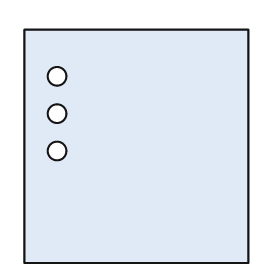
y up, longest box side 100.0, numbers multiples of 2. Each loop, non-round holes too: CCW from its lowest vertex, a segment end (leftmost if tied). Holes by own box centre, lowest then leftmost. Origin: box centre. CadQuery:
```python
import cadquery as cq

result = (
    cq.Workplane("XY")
    .moveTo(-48.0, -50.0)
    .lineTo(48.0, -50.0)
    .lineTo(48.0, 50.0)
    .lineTo(-48.0, 50.0)
    .close()
    .moveTo(-34.0, -2.0)
    .circle(4.0)
    .moveTo(-34.0, 14.0)
    .circle(4.0)
    .moveTo(-34.0, 30.0)
    .circle(4.0)
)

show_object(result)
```